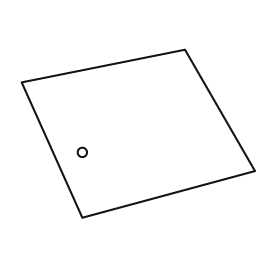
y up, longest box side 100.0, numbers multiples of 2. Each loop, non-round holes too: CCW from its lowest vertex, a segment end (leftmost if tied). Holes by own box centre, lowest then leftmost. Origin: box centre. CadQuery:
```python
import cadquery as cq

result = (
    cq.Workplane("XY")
    .moveTo(-24.0, -36.0)
    .lineTo(50.0, -16.0)
    .lineTo(20.0, 36.0)
    .lineTo(-50.0, 22.0)
    .close()
    .moveTo(-24.0, -8.0)
    .circle(2.0)
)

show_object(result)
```